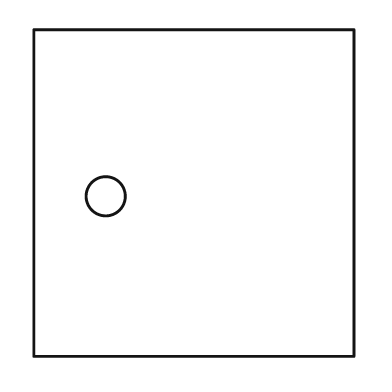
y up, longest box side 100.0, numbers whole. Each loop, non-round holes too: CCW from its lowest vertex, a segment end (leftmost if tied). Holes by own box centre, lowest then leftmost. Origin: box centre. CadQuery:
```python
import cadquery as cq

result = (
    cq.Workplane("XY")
    .moveTo(-49.0, -50.0)
    .lineTo(49.0, -50.0)
    .lineTo(49.0, 50.0)
    .lineTo(-49.0, 50.0)
    .close()
    .moveTo(-27.0, -1.0)
    .circle(6.0)
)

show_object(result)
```